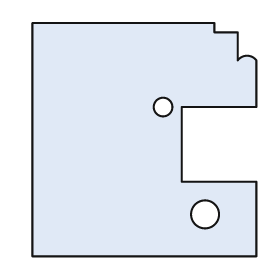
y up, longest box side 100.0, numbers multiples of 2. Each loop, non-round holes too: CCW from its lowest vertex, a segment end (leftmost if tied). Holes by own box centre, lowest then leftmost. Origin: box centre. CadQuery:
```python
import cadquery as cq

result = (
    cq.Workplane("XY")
    .moveTo(-48.0, -50.0)
    .lineTo(48.0, -50.0)
    .lineTo(48.0, -18.0)
    .lineTo(16.0, -18.0)
    .lineTo(16.0, 14.0)
    .lineTo(48.0, 14.0)
    .lineTo(48.0, 34.0)
    .threePointArc((44.0, 36.0), (40.0, 34.0))
    .lineTo(40.0, 46.0)
    .lineTo(30.0, 46.0)
    .lineTo(30.0, 50.0)
    .lineTo(-48.0, 50.0)
    .close()
    .moveTo(26.0, -32.0)
    .circle(6.0)
    .moveTo(8.0, 14.0)
    .circle(4.0)
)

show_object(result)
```